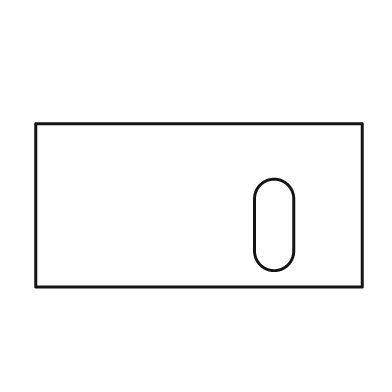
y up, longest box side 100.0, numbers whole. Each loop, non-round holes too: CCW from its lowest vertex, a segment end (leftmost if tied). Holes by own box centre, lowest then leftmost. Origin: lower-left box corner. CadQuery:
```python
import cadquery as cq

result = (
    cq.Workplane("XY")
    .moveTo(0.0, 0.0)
    .lineTo(100.0, 0.0)
    .lineTo(100.0, 50.0)
    .lineTo(0.0, 50.0)
    .close()
    .moveTo(67.0, 11.0)
    .threePointArc((73.0, 5.0), (79.0, 11.0))
    .lineTo(79.0, 27.0)
    .threePointArc((73.0, 33.0), (67.0, 27.0))
    .close()
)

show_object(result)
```